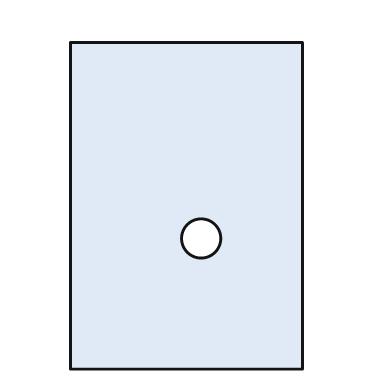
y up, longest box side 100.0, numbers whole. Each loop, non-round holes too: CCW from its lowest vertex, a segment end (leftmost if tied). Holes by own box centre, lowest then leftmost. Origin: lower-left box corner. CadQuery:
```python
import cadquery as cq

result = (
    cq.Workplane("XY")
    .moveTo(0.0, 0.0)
    .lineTo(71.0, 0.0)
    .lineTo(71.0, 100.0)
    .lineTo(0.0, 100.0)
    .close()
    .moveTo(40.0, 40.0)
    .circle(6.0)
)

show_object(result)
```